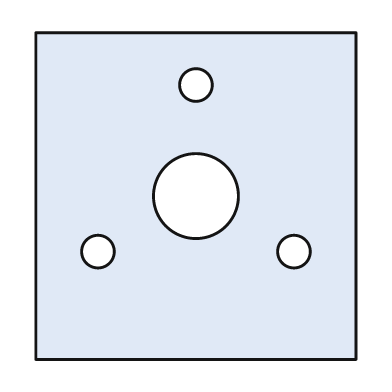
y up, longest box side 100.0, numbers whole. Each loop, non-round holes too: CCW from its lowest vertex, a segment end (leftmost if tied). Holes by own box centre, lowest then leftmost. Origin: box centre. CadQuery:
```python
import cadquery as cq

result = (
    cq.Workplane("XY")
    .moveTo(-49.0, -50.0)
    .lineTo(49.0, -50.0)
    .lineTo(49.0, 50.0)
    .lineTo(-49.0, 50.0)
    .close()
    .moveTo(-30.0, -17.0)
    .circle(5.0)
    .moveTo(30.0, -17.0)
    .circle(5.0)
    .moveTo(0.0, 0.0)
    .circle(13.0)
    .moveTo(0.0, 34.0)
    .circle(5.0)
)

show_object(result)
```